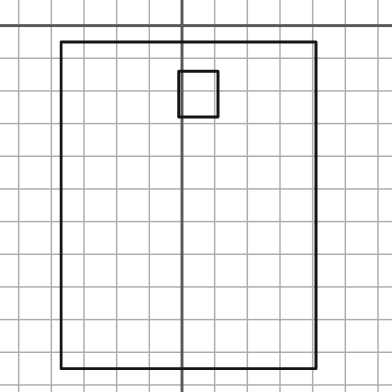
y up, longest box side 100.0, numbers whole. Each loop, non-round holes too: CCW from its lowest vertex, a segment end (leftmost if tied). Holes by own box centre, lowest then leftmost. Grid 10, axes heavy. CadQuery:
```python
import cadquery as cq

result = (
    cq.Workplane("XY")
    .moveTo(-37.0, -105.0)
    .lineTo(41.0, -105.0)
    .lineTo(41.0, -5.0)
    .lineTo(-37.0, -5.0)
    .close()
    .moveTo(-1.0, -28.0)
    .lineTo(11.0, -28.0)
    .lineTo(11.0, -14.0)
    .lineTo(-1.0, -14.0)
    .close()
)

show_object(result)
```